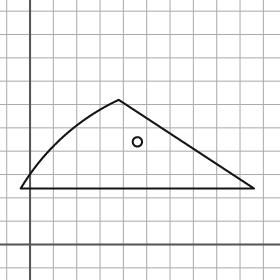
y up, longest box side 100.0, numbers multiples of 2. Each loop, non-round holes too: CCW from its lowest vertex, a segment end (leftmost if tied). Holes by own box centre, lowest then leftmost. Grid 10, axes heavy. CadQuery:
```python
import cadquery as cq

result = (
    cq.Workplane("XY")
    .moveTo(-4.0, 24.0)
    .lineTo(96.0, 24.0)
    .lineTo(38.0, 62.0)
    .threePointArc((14.0, 46.0), (-4.0, 24.0))
    .close()
    .moveTo(46.0, 44.0)
    .circle(2.0)
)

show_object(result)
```